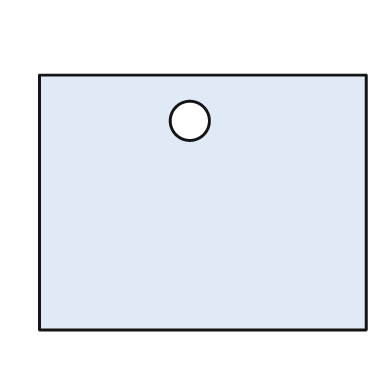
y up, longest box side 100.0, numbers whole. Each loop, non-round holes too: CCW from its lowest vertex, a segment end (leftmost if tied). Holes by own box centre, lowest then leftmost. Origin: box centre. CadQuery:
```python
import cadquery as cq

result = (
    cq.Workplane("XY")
    .moveTo(-50.0, -39.0)
    .lineTo(50.0, -39.0)
    .lineTo(50.0, 39.0)
    .lineTo(-50.0, 39.0)
    .close()
    .moveTo(-4.0, 25.0)
    .circle(6.0)
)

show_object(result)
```